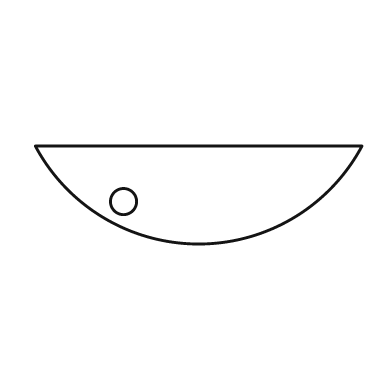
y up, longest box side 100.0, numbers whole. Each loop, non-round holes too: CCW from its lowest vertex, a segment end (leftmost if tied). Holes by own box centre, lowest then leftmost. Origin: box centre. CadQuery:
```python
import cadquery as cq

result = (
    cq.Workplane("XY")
    .moveTo(-50.0, 15.0)
    .threePointArc((0.0, -15.0), (50.0, 15.0))
    .close()
    .moveTo(-23.0, -2.0)
    .circle(4.0)
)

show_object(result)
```